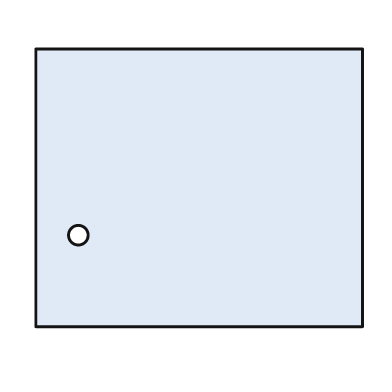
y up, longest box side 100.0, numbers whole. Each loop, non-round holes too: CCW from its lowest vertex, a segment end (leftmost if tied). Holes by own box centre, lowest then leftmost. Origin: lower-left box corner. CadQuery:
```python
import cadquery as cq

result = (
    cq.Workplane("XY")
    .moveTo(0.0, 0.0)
    .lineTo(100.0, 0.0)
    .lineTo(100.0, 85.0)
    .lineTo(0.0, 85.0)
    .close()
    .moveTo(13.0, 28.0)
    .circle(3.0)
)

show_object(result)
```